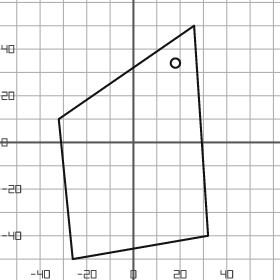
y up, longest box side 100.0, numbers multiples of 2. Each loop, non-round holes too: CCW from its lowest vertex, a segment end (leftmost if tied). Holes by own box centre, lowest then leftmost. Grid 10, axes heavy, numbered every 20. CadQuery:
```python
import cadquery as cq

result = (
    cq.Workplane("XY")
    .moveTo(-26.0, -50.0)
    .lineTo(32.0, -40.0)
    .lineTo(26.0, 50.0)
    .lineTo(-32.0, 10.0)
    .close()
    .moveTo(18.0, 34.0)
    .circle(2.0)
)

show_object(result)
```